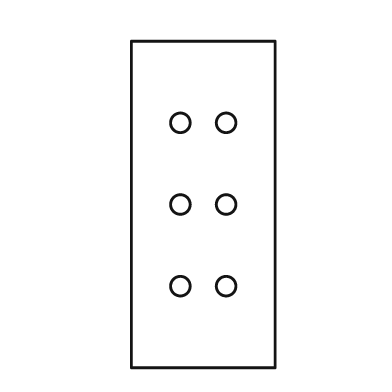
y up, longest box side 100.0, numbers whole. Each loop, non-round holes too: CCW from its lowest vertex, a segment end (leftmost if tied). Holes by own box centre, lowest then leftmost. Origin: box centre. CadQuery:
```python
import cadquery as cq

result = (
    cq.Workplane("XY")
    .moveTo(-22.0, -50.0)
    .lineTo(22.0, -50.0)
    .lineTo(22.0, 50.0)
    .lineTo(-22.0, 50.0)
    .close()
    .moveTo(-7.0, -25.0)
    .circle(3.0)
    .moveTo(7.0, -25.0)
    .circle(3.0)
    .moveTo(-7.0, 0.0)
    .circle(3.0)
    .moveTo(7.0, 0.0)
    .circle(3.0)
    .moveTo(-7.0, 25.0)
    .circle(3.0)
    .moveTo(7.0, 25.0)
    .circle(3.0)
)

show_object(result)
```